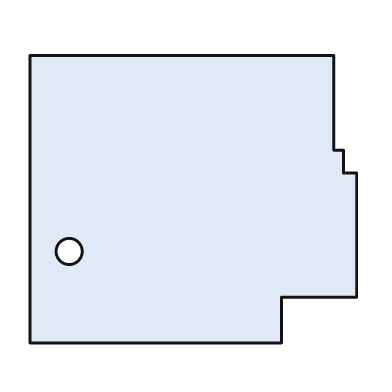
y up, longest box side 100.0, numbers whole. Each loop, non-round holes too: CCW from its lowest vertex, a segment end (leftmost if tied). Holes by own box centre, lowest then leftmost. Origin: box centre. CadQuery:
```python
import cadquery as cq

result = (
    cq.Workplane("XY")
    .moveTo(-50.0, -44.0)
    .lineTo(27.0, -44.0)
    .lineTo(27.0, -30.0)
    .lineTo(50.0, -30.0)
    .lineTo(50.0, 8.0)
    .lineTo(46.0, 8.0)
    .lineTo(46.0, 15.0)
    .lineTo(43.0, 15.0)
    .lineTo(43.0, 44.0)
    .lineTo(-50.0, 44.0)
    .close()
    .moveTo(-38.0, -16.0)
    .circle(4.0)
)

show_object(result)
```